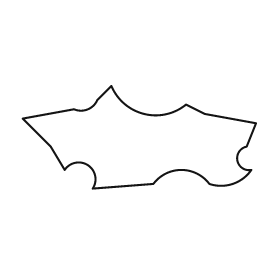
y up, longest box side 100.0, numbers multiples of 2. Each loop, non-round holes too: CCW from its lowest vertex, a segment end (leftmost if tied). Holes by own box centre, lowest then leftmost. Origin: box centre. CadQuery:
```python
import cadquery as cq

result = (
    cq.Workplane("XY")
    .moveTo(-20.0, -22.0)
    .lineTo(6.0, -20.0)
    .threePointArc((18.0, -14.0), (30.0, -20.0))
    .threePointArc((40.0, -20.0), (48.0, -14.0))
    .threePointArc((42.0, -10.0), (46.0, -4.0))
    .lineTo(50.0, 6.0)
    .lineTo(28.0, 10.0)
    .lineTo(20.0, 14.0)
    .threePointArc((2.0, 10.0), (-12.0, 22.0))
    .lineTo(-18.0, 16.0)
    .threePointArc((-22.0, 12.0), (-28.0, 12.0))
    .lineTo(-50.0, 8.0)
    .lineTo(-38.0, -4.0)
    .lineTo(-32.0, -14.0)
    .threePointArc((-22.0, -12.0), (-20.0, -22.0))
    .close()
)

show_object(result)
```